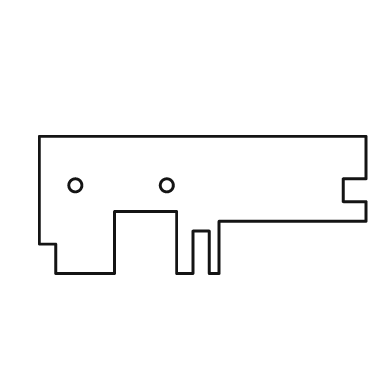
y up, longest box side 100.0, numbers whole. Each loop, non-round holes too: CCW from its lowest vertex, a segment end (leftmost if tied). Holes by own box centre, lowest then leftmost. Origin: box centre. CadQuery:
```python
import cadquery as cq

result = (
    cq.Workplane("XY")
    .moveTo(-45.0, -21.0)
    .lineTo(-27.0, -21.0)
    .lineTo(-27.0, -2.0)
    .lineTo(-8.0, -2.0)
    .lineTo(-8.0, -21.0)
    .lineTo(-3.0, -21.0)
    .lineTo(-3.0, -8.0)
    .lineTo(2.0, -8.0)
    .lineTo(2.0, -21.0)
    .lineTo(5.0, -21.0)
    .lineTo(5.0, -5.0)
    .lineTo(50.0, -5.0)
    .lineTo(50.0, 1.0)
    .lineTo(43.0, 1.0)
    .lineTo(43.0, 8.0)
    .lineTo(50.0, 8.0)
    .lineTo(50.0, 21.0)
    .lineTo(-50.0, 21.0)
    .lineTo(-50.0, -12.0)
    .lineTo(-45.0, -12.0)
    .close()
    .moveTo(-39.0, 6.0)
    .circle(2.0)
    .moveTo(-11.0, 6.0)
    .circle(2.0)
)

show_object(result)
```